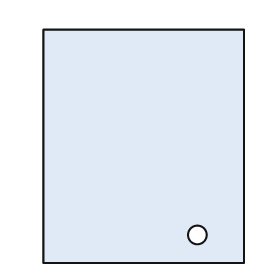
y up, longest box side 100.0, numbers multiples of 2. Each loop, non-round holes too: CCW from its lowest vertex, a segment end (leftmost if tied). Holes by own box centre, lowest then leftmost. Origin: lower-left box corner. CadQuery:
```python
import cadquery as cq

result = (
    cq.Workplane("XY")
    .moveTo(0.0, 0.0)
    .lineTo(86.0, 0.0)
    .lineTo(86.0, 100.0)
    .lineTo(0.0, 100.0)
    .close()
    .moveTo(66.0, 12.0)
    .circle(4.0)
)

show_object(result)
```